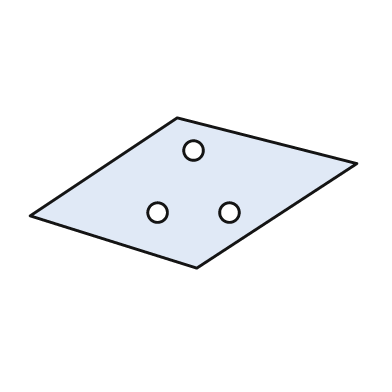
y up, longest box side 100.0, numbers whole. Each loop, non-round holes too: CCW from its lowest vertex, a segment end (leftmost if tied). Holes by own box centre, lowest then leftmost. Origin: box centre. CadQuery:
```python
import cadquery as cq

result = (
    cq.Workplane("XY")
    .moveTo(1.0, -23.0)
    .lineTo(50.0, 9.0)
    .lineTo(-5.0, 23.0)
    .lineTo(-50.0, -7.0)
    .close()
    .moveTo(-11.0, -6.0)
    .circle(3.0)
    .moveTo(11.0, -6.0)
    .circle(3.0)
    .moveTo(0.0, 13.0)
    .circle(3.0)
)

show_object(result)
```